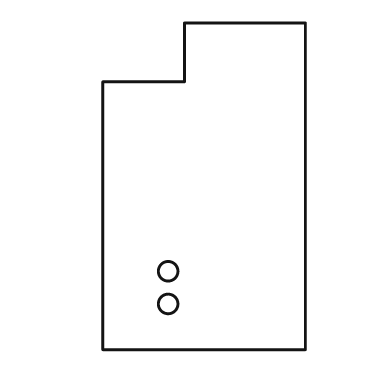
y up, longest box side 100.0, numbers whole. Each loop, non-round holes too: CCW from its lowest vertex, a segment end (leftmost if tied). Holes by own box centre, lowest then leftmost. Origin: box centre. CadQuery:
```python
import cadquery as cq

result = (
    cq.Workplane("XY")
    .moveTo(-31.0, -50.0)
    .lineTo(31.0, -50.0)
    .lineTo(31.0, 50.0)
    .lineTo(-6.0, 50.0)
    .lineTo(-6.0, 32.0)
    .lineTo(-31.0, 32.0)
    .close()
    .moveTo(-11.0, -36.0)
    .circle(3.0)
    .moveTo(-11.0, -26.0)
    .circle(3.0)
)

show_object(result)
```